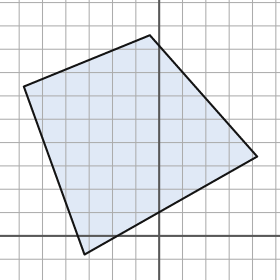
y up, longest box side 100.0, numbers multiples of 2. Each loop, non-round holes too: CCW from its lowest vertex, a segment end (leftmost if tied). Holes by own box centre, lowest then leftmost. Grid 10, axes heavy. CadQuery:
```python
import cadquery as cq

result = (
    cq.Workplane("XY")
    .moveTo(-32.0, -8.0)
    .lineTo(42.0, 34.0)
    .lineTo(-4.0, 86.0)
    .lineTo(-58.0, 64.0)
    .close()
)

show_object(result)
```